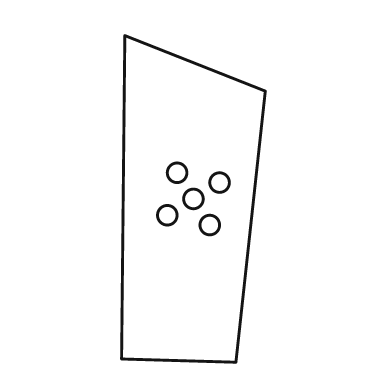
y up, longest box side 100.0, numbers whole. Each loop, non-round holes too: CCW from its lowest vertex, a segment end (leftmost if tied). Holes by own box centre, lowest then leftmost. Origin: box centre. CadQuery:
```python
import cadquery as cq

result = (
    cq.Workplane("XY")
    .moveTo(13.0, -50.0)
    .lineTo(22.0, 33.0)
    .lineTo(-21.0, 50.0)
    .lineTo(-22.0, -49.0)
    .close()
    .moveTo(5.0, -8.0)
    .circle(3.0)
    .moveTo(-8.0, -5.0)
    .circle(3.0)
    .moveTo(0.0, 0.0)
    .circle(3.0)
    .moveTo(8.0, 5.0)
    .circle(3.0)
    .moveTo(-5.0, 8.0)
    .circle(3.0)
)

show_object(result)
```